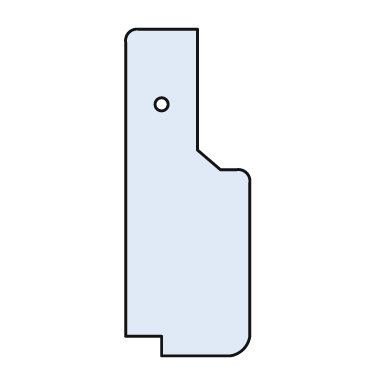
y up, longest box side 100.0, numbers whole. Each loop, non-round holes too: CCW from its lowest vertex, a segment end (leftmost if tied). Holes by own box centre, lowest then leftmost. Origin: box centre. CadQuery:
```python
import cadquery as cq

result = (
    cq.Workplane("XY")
    .moveTo(-8.0, -50.0)
    .lineTo(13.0, -50.0)
    .threePointArc((17.0, -48.0), (19.0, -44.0))
    .lineTo(19.0, 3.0)
    .threePointArc((18.0, 6.0), (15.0, 7.0))
    .lineTo(10.0, 7.0)
    .lineTo(3.0, 13.0)
    .lineTo(3.0, 50.0)
    .lineTo(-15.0, 50.0)
    .threePointArc((-18.0, 49.0), (-19.0, 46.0))
    .lineTo(-19.0, -44.0)
    .lineTo(-8.0, -44.0)
    .close()
    .moveTo(-8.0, 27.0)
    .circle(2.0)
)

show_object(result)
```